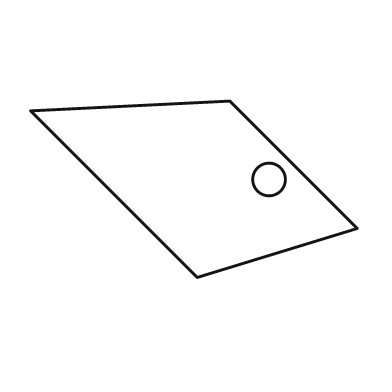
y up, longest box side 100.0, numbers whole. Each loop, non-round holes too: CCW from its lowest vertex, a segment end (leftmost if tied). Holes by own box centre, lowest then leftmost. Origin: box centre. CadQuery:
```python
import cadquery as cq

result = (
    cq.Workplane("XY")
    .moveTo(1.0, -27.0)
    .lineTo(50.0, -12.0)
    .lineTo(11.0, 27.0)
    .lineTo(-50.0, 24.0)
    .close()
    .moveTo(23.0, 3.0)
    .circle(5.0)
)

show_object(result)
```